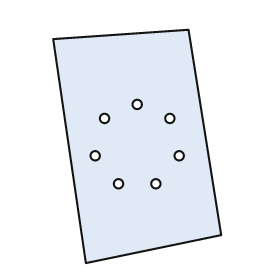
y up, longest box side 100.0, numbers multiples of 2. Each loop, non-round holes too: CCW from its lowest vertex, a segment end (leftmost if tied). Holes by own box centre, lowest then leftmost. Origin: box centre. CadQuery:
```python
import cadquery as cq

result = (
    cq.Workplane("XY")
    .moveTo(-22.0, -50.0)
    .lineTo(36.0, -38.0)
    .lineTo(22.0, 50.0)
    .lineTo(-36.0, 46.0)
    .close()
    .moveTo(-8.0, -16.0)
    .circle(2.0)
    .moveTo(8.0, -16.0)
    .circle(2.0)
    .moveTo(-18.0, -4.0)
    .circle(2.0)
    .moveTo(18.0, -4.0)
    .circle(2.0)
    .moveTo(-14.0, 12.0)
    .circle(2.0)
    .moveTo(14.0, 12.0)
    .circle(2.0)
    .moveTo(0.0, 18.0)
    .circle(2.0)
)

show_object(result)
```